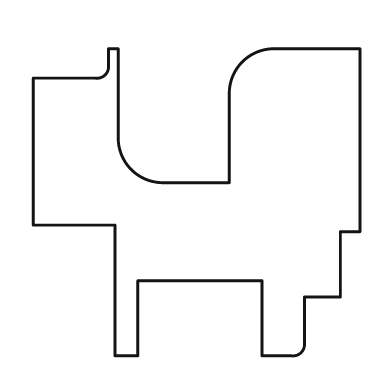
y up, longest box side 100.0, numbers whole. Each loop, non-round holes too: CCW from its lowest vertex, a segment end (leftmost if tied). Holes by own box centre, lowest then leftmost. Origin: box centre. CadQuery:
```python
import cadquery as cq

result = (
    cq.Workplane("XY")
    .moveTo(-25.0, -47.0)
    .lineTo(-18.0, -47.0)
    .lineTo(-18.0, -24.0)
    .lineTo(20.0, -24.0)
    .lineTo(20.0, -47.0)
    .lineTo(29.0, -47.0)
    .threePointArc((32.0, -46.0), (33.0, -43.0))
    .lineTo(33.0, -29.0)
    .lineTo(44.0, -29.0)
    .lineTo(44.0, -9.0)
    .lineTo(50.0, -9.0)
    .lineTo(50.0, 47.0)
    .lineTo(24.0, 47.0)
    .threePointArc((14.0, 43.0), (10.0, 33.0))
    .lineTo(10.0, 6.0)
    .lineTo(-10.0, 6.0)
    .threePointArc((-20.0, 10.0), (-24.0, 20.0))
    .lineTo(-24.0, 47.0)
    .lineTo(-27.0, 47.0)
    .lineTo(-27.0, 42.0)
    .threePointArc((-28.0, 39.0), (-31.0, 38.0))
    .lineTo(-50.0, 38.0)
    .lineTo(-50.0, -7.0)
    .lineTo(-25.0, -7.0)
    .close()
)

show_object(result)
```